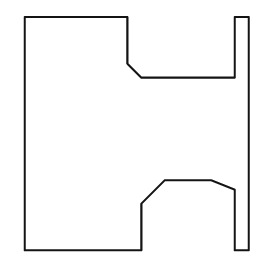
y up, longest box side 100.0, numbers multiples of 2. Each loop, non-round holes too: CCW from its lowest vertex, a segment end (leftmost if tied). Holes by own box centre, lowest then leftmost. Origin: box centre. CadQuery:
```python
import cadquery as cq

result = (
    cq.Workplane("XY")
    .moveTo(-48.0, -50.0)
    .lineTo(2.0, -50.0)
    .lineTo(2.0, -30.0)
    .lineTo(12.0, -20.0)
    .lineTo(32.0, -20.0)
    .lineTo(42.0, -24.0)
    .lineTo(42.0, -50.0)
    .lineTo(48.0, -50.0)
    .lineTo(48.0, 50.0)
    .lineTo(42.0, 50.0)
    .lineTo(42.0, 24.0)
    .lineTo(2.0, 24.0)
    .lineTo(-4.0, 30.0)
    .lineTo(-4.0, 50.0)
    .lineTo(-48.0, 50.0)
    .close()
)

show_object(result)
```